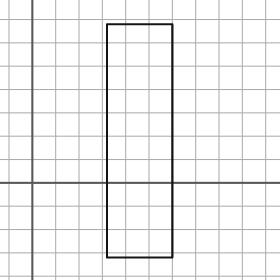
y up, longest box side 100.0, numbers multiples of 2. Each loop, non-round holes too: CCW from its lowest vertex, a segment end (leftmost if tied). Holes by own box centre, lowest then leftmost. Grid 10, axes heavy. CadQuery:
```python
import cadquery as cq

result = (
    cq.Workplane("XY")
    .moveTo(32.0, -32.0)
    .lineTo(60.0, -32.0)
    .lineTo(60.0, 68.0)
    .lineTo(32.0, 68.0)
    .close()
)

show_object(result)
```